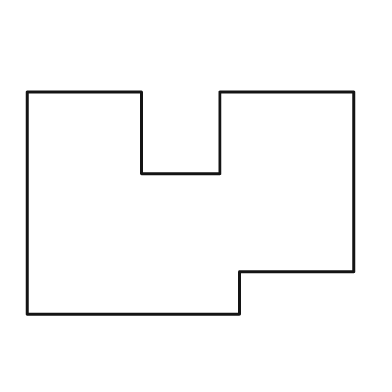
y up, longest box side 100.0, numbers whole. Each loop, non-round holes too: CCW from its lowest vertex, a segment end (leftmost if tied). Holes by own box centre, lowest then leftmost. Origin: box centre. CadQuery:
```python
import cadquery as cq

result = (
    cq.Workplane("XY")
    .moveTo(-50.0, -34.0)
    .lineTo(15.0, -34.0)
    .lineTo(15.0, -21.0)
    .lineTo(50.0, -21.0)
    .lineTo(50.0, 34.0)
    .lineTo(9.0, 34.0)
    .lineTo(9.0, 9.0)
    .lineTo(-15.0, 9.0)
    .lineTo(-15.0, 34.0)
    .lineTo(-50.0, 34.0)
    .close()
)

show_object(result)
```